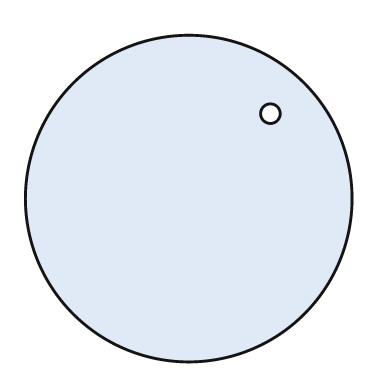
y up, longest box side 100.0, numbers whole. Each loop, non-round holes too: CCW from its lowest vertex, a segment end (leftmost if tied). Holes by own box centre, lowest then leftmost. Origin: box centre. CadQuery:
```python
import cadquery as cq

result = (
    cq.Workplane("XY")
    .moveTo(0.0, 0.0)
    .circle(50.0)
    .moveTo(25.0, 26.0)
    .circle(3.0)
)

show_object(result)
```